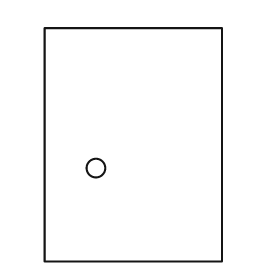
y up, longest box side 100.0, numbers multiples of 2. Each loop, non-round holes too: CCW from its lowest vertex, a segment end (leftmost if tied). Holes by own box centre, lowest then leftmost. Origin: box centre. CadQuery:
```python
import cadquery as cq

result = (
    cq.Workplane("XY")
    .moveTo(-38.0, -50.0)
    .lineTo(38.0, -50.0)
    .lineTo(38.0, 50.0)
    .lineTo(-38.0, 50.0)
    .close()
    .moveTo(-16.0, -10.0)
    .circle(4.0)
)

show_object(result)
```